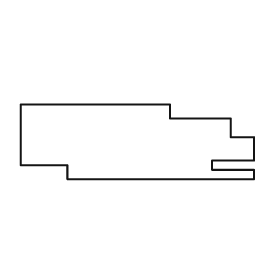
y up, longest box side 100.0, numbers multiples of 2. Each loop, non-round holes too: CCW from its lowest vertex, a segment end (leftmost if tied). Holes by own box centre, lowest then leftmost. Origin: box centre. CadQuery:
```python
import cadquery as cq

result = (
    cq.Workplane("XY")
    .moveTo(-30.0, -16.0)
    .lineTo(50.0, -16.0)
    .lineTo(50.0, -12.0)
    .lineTo(32.0, -12.0)
    .lineTo(32.0, -8.0)
    .lineTo(50.0, -8.0)
    .lineTo(50.0, 2.0)
    .lineTo(40.0, 2.0)
    .lineTo(40.0, 10.0)
    .lineTo(14.0, 10.0)
    .lineTo(14.0, 16.0)
    .lineTo(-50.0, 16.0)
    .lineTo(-50.0, -10.0)
    .lineTo(-30.0, -10.0)
    .close()
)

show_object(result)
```